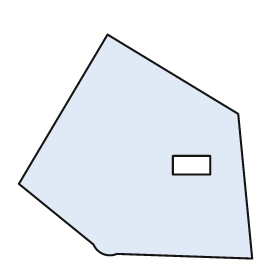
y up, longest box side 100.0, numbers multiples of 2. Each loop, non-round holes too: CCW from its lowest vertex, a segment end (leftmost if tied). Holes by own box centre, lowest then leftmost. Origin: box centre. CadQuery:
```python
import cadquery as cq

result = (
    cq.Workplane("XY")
    .moveTo(50.0, -48.0)
    .lineTo(44.0, 14.0)
    .lineTo(-12.0, 48.0)
    .lineTo(-50.0, -16.0)
    .lineTo(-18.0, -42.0)
    .threePointArc((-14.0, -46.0), (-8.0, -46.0))
    .close()
    .moveTo(16.0, -12.0)
    .lineTo(32.0, -12.0)
    .lineTo(32.0, -4.0)
    .lineTo(16.0, -4.0)
    .close()
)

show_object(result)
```